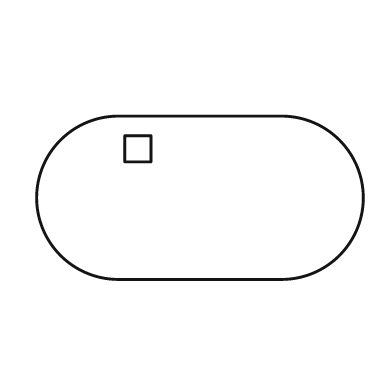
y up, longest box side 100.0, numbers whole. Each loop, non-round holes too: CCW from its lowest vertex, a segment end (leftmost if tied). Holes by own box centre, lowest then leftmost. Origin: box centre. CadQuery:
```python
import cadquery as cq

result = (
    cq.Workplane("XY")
    .moveTo(-25.0, -25.0)
    .lineTo(25.0, -25.0)
    .threePointArc((50.0, 0.0), (25.0, 25.0))
    .lineTo(-25.0, 25.0)
    .threePointArc((-50.0, 0.0), (-25.0, -25.0))
    .close()
    .moveTo(-23.0, 11.0)
    .lineTo(-15.0, 11.0)
    .lineTo(-15.0, 19.0)
    .lineTo(-23.0, 19.0)
    .close()
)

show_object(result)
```